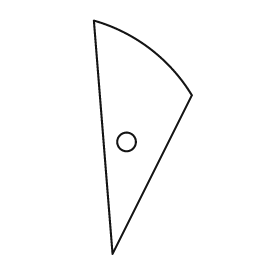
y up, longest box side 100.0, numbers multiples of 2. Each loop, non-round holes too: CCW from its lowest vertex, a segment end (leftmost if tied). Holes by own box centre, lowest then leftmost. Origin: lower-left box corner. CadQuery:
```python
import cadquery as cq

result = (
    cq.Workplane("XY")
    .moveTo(8.0, 0.0)
    .lineTo(42.0, 68.0)
    .threePointArc((24.0, 88.0), (0.0, 100.0))
    .close()
    .moveTo(14.0, 48.0)
    .circle(4.0)
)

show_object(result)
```